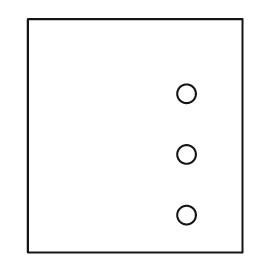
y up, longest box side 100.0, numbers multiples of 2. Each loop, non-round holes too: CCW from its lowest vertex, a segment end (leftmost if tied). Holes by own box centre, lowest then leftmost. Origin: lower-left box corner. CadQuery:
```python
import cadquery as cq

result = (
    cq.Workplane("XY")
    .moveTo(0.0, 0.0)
    .lineTo(92.0, 0.0)
    .lineTo(92.0, 100.0)
    .lineTo(0.0, 100.0)
    .close()
    .moveTo(68.0, 16.0)
    .circle(4.0)
    .moveTo(68.0, 42.0)
    .circle(4.0)
    .moveTo(68.0, 68.0)
    .circle(4.0)
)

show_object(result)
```